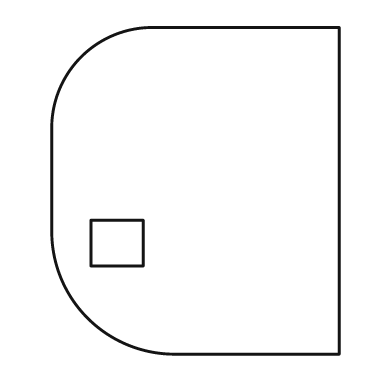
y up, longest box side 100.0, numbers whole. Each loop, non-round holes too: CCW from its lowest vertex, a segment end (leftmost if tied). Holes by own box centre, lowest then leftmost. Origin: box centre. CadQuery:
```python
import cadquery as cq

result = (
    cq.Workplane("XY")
    .moveTo(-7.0, -50.0)
    .lineTo(44.0, -50.0)
    .lineTo(44.0, 50.0)
    .lineTo(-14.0, 50.0)
    .threePointArc((-35.0, 41.0), (-44.0, 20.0))
    .lineTo(-44.0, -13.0)
    .threePointArc((-33.0, -39.0), (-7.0, -50.0))
    .close()
    .moveTo(-32.0, -23.0)
    .lineTo(-16.0, -23.0)
    .lineTo(-16.0, -9.0)
    .lineTo(-32.0, -9.0)
    .close()
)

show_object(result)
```